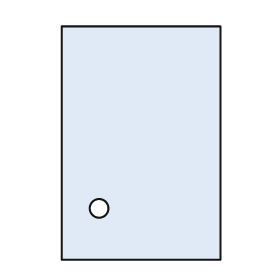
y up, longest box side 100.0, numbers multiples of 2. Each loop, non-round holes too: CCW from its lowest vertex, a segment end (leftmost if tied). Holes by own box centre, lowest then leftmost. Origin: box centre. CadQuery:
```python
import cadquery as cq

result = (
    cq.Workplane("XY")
    .moveTo(-34.0, -50.0)
    .lineTo(34.0, -50.0)
    .lineTo(34.0, 50.0)
    .lineTo(-34.0, 50.0)
    .close()
    .moveTo(-18.0, -28.0)
    .circle(4.0)
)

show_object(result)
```